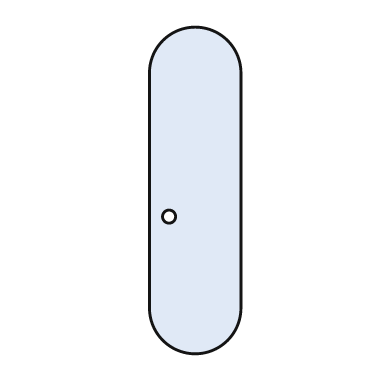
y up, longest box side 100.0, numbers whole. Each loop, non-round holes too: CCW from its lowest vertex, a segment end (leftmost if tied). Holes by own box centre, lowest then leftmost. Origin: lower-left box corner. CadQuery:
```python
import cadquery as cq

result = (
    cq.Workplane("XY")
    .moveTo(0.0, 14.0)
    .threePointArc((14.0, 0.0), (28.0, 14.0))
    .lineTo(28.0, 86.0)
    .threePointArc((14.0, 100.0), (0.0, 86.0))
    .close()
    .moveTo(6.0, 42.0)
    .circle(2.0)
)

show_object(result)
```